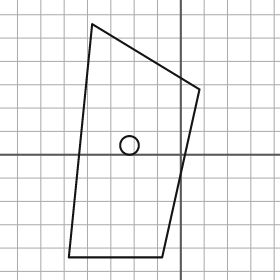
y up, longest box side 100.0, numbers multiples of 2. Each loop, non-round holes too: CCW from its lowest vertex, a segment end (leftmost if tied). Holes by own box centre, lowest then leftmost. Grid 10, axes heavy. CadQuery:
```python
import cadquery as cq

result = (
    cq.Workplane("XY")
    .moveTo(-48.0, -44.0)
    .lineTo(-8.0, -44.0)
    .lineTo(8.0, 28.0)
    .lineTo(-38.0, 56.0)
    .close()
    .moveTo(-22.0, 4.0)
    .circle(4.0)
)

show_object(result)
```